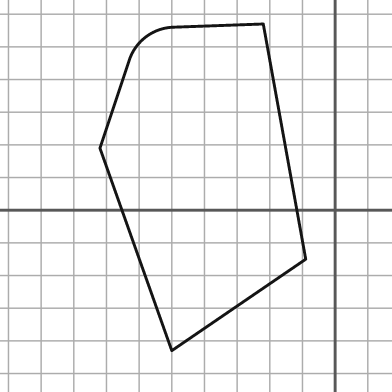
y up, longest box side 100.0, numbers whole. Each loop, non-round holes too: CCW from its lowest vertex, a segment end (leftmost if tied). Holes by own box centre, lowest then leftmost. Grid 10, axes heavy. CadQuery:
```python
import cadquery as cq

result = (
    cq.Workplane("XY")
    .moveTo(-50.0, -43.0)
    .lineTo(-9.0, -15.0)
    .lineTo(-22.0, 57.0)
    .lineTo(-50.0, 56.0)
    .threePointArc((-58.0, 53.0), (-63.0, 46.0))
    .lineTo(-72.0, 19.0)
    .close()
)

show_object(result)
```